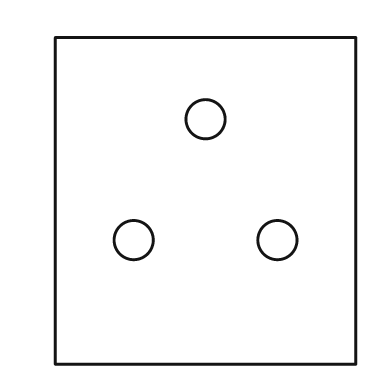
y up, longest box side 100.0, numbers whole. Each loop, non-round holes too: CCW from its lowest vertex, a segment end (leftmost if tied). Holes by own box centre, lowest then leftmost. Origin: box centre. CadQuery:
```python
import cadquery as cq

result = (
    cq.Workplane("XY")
    .moveTo(-46.0, -50.0)
    .lineTo(46.0, -50.0)
    .lineTo(46.0, 50.0)
    .lineTo(-46.0, 50.0)
    .close()
    .moveTo(-22.0, -12.0)
    .circle(6.0)
    .moveTo(22.0, -12.0)
    .circle(6.0)
    .moveTo(0.0, 25.0)
    .circle(6.0)
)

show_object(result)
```